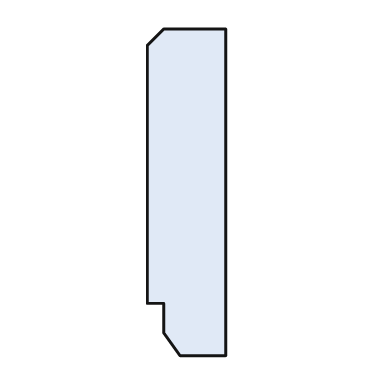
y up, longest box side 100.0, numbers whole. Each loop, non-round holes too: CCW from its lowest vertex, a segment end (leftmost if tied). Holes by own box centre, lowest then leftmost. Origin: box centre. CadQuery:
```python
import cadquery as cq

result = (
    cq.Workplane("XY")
    .moveTo(-2.0, -50.0)
    .lineTo(12.0, -50.0)
    .lineTo(12.0, 50.0)
    .lineTo(-7.0, 50.0)
    .lineTo(-12.0, 45.0)
    .lineTo(-12.0, -34.0)
    .lineTo(-7.0, -34.0)
    .lineTo(-7.0, -43.0)
    .close()
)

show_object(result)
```